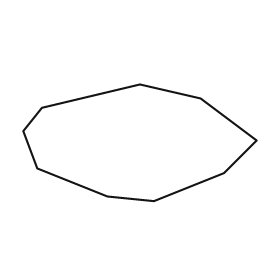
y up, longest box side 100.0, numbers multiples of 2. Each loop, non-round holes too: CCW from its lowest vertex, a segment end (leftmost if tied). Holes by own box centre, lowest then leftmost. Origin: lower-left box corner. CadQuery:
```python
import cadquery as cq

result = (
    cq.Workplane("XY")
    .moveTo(56.0, 0.0)
    .lineTo(86.0, 12.0)
    .lineTo(100.0, 26.0)
    .lineTo(76.0, 44.0)
    .lineTo(50.0, 50.0)
    .lineTo(8.0, 40.0)
    .lineTo(0.0, 30.0)
    .lineTo(6.0, 14.0)
    .lineTo(36.0, 2.0)
    .close()
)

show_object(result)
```